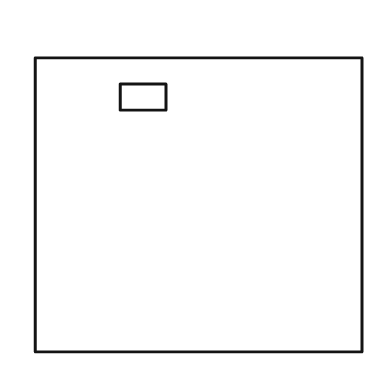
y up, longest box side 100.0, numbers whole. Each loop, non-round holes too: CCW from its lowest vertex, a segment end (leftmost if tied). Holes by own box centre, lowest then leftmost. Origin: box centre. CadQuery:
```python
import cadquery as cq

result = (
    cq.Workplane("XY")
    .moveTo(-50.0, -45.0)
    .lineTo(50.0, -45.0)
    .lineTo(50.0, 45.0)
    .lineTo(-50.0, 45.0)
    .close()
    .moveTo(-24.0, 29.0)
    .lineTo(-10.0, 29.0)
    .lineTo(-10.0, 37.0)
    .lineTo(-24.0, 37.0)
    .close()
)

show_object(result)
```